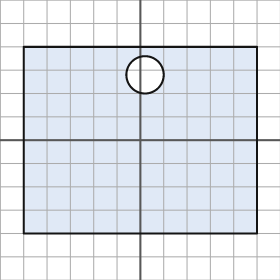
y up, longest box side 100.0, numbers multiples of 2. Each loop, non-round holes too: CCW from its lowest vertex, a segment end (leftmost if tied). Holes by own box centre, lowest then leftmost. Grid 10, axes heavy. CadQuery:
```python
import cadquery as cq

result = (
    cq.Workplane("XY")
    .moveTo(-50.0, -40.0)
    .lineTo(50.0, -40.0)
    .lineTo(50.0, 40.0)
    .lineTo(-50.0, 40.0)
    .close()
    .moveTo(2.0, 28.0)
    .circle(8.0)
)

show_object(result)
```